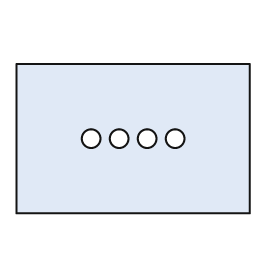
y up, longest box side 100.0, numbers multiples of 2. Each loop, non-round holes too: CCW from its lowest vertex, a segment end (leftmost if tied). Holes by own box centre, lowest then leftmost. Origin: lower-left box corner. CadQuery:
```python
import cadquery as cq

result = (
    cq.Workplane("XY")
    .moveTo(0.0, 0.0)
    .lineTo(100.0, 0.0)
    .lineTo(100.0, 64.0)
    .lineTo(0.0, 64.0)
    .close()
    .moveTo(32.0, 32.0)
    .circle(4.0)
    .moveTo(44.0, 32.0)
    .circle(4.0)
    .moveTo(56.0, 32.0)
    .circle(4.0)
    .moveTo(68.0, 32.0)
    .circle(4.0)
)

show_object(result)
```